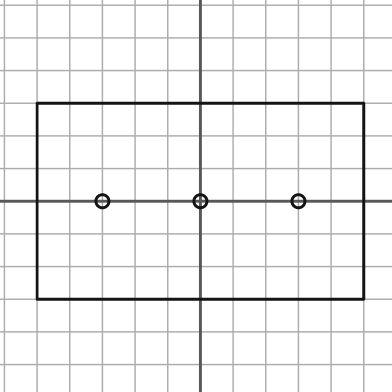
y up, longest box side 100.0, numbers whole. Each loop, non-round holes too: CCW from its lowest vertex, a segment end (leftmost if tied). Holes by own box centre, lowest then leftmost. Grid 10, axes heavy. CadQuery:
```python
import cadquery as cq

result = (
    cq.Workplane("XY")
    .moveTo(-50.0, -30.0)
    .lineTo(50.0, -30.0)
    .lineTo(50.0, 30.0)
    .lineTo(-50.0, 30.0)
    .close()
    .moveTo(-30.0, 0.0)
    .circle(2.0)
    .moveTo(0.0, 0.0)
    .circle(2.0)
    .moveTo(30.0, 0.0)
    .circle(2.0)
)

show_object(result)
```